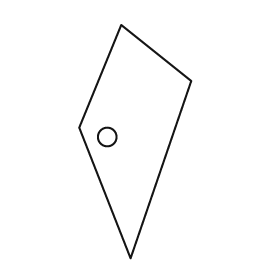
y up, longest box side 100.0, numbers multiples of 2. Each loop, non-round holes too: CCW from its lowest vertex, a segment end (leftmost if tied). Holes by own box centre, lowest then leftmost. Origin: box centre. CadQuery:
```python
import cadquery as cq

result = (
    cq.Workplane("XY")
    .moveTo(-2.0, -50.0)
    .lineTo(24.0, 26.0)
    .lineTo(-6.0, 50.0)
    .lineTo(-24.0, 6.0)
    .close()
    .moveTo(-12.0, 2.0)
    .circle(4.0)
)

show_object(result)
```